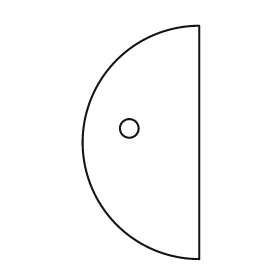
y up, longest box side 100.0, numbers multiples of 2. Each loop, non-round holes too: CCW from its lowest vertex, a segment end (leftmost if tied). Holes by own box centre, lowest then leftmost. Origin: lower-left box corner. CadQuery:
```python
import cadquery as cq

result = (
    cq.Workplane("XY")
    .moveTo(50.0, 0.0)
    .lineTo(50.0, 100.0)
    .threePointArc((0.0, 50.0), (50.0, 0.0))
    .close()
    .moveTo(20.0, 56.0)
    .circle(4.0)
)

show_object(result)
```